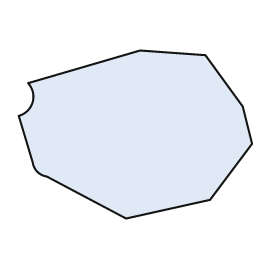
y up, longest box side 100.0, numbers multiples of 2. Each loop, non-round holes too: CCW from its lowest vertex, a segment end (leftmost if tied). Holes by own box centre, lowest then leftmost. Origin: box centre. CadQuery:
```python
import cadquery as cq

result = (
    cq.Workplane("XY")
    .moveTo(-4.0, -36.0)
    .lineTo(32.0, -28.0)
    .lineTo(50.0, -4.0)
    .lineTo(46.0, 12.0)
    .lineTo(30.0, 34.0)
    .lineTo(2.0, 36.0)
    .lineTo(-46.0, 22.0)
    .threePointArc((-44.0, 14.0), (-50.0, 8.0))
    .lineTo(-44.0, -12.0)
    .threePointArc((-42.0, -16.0), (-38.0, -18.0))
    .close()
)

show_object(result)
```